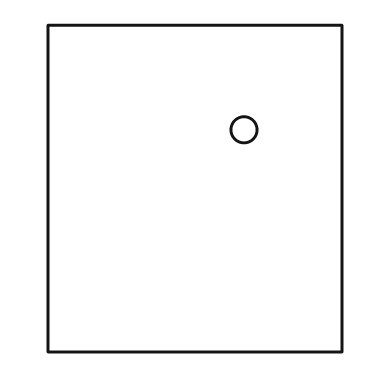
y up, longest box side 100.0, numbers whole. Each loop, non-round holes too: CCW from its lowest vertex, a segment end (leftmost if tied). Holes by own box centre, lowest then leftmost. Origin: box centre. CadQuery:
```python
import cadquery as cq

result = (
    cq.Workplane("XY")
    .moveTo(-45.0, -50.0)
    .lineTo(45.0, -50.0)
    .lineTo(45.0, 50.0)
    .lineTo(-45.0, 50.0)
    .close()
    .moveTo(15.0, 18.0)
    .circle(4.0)
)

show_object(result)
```